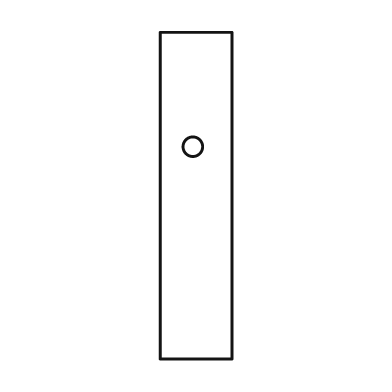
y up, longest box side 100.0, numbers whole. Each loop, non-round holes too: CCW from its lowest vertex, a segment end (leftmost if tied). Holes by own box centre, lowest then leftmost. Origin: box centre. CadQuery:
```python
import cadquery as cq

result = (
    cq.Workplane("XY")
    .moveTo(-11.0, -50.0)
    .lineTo(11.0, -50.0)
    .lineTo(11.0, 50.0)
    .lineTo(-11.0, 50.0)
    .close()
    .moveTo(-1.0, 15.0)
    .circle(3.0)
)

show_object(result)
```